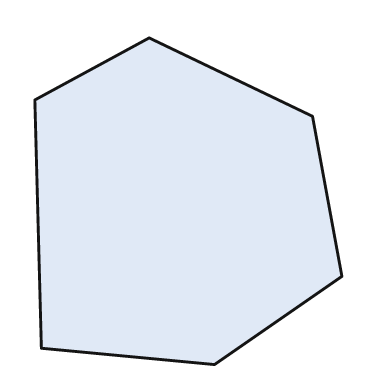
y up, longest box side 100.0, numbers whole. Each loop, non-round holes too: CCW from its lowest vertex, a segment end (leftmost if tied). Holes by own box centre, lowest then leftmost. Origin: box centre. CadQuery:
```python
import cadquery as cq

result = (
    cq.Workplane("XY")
    .moveTo(8.0, -50.0)
    .lineTo(47.0, -23.0)
    .lineTo(38.0, 26.0)
    .lineTo(-12.0, 50.0)
    .lineTo(-47.0, 31.0)
    .lineTo(-45.0, -45.0)
    .close()
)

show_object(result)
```